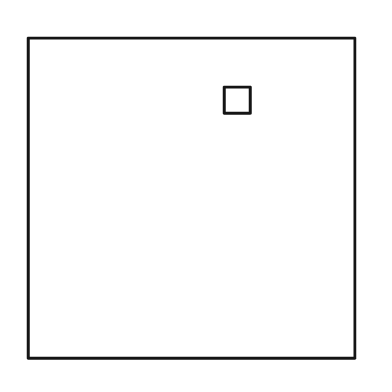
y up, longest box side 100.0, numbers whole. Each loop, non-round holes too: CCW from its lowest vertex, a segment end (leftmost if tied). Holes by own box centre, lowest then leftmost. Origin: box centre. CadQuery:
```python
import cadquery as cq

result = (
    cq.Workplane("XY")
    .moveTo(-50.0, -49.0)
    .lineTo(50.0, -49.0)
    .lineTo(50.0, 49.0)
    .lineTo(-50.0, 49.0)
    .close()
    .moveTo(10.0, 26.0)
    .lineTo(18.0, 26.0)
    .lineTo(18.0, 34.0)
    .lineTo(10.0, 34.0)
    .close()
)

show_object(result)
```